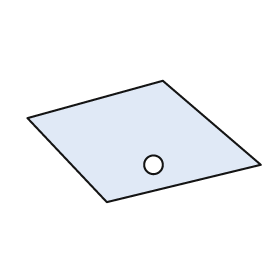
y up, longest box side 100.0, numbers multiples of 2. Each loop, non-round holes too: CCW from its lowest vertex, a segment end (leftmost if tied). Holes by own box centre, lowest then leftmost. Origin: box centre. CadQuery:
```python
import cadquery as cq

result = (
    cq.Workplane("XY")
    .moveTo(-16.0, -26.0)
    .lineTo(50.0, -10.0)
    .lineTo(8.0, 26.0)
    .lineTo(-50.0, 10.0)
    .close()
    .moveTo(4.0, -10.0)
    .circle(4.0)
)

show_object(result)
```